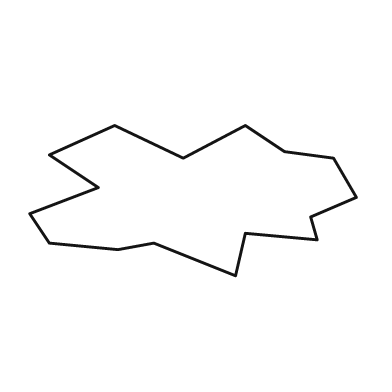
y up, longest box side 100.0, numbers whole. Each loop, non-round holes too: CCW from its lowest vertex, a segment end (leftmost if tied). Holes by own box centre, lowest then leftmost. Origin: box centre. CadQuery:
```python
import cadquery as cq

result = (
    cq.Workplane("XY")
    .moveTo(13.0, -23.0)
    .lineTo(16.0, -10.0)
    .lineTo(38.0, -12.0)
    .lineTo(36.0, -5.0)
    .lineTo(50.0, 1.0)
    .lineTo(43.0, 13.0)
    .lineTo(28.0, 15.0)
    .lineTo(16.0, 23.0)
    .lineTo(-3.0, 13.0)
    .lineTo(-24.0, 23.0)
    .lineTo(-44.0, 14.0)
    .lineTo(-29.0, 4.0)
    .lineTo(-50.0, -4.0)
    .lineTo(-44.0, -13.0)
    .lineTo(-23.0, -15.0)
    .lineTo(-12.0, -13.0)
    .close()
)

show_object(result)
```